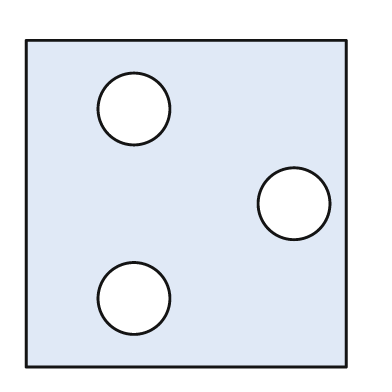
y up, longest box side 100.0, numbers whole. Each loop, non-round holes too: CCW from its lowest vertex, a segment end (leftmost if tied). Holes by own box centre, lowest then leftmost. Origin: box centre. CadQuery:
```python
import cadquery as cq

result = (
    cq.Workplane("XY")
    .moveTo(-49.0, -50.0)
    .lineTo(49.0, -50.0)
    .lineTo(49.0, 50.0)
    .lineTo(-49.0, 50.0)
    .close()
    .moveTo(-16.0, -29.0)
    .circle(11.0)
    .moveTo(33.0, 0.0)
    .circle(11.0)
    .moveTo(-16.0, 29.0)
    .circle(11.0)
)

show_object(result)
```